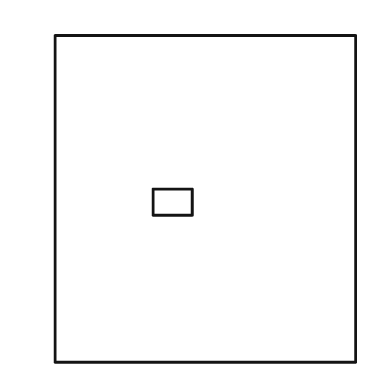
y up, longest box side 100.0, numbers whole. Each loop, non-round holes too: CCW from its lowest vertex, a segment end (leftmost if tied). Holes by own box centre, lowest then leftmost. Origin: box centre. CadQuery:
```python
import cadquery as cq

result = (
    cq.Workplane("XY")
    .moveTo(-46.0, -50.0)
    .lineTo(46.0, -50.0)
    .lineTo(46.0, 50.0)
    .lineTo(-46.0, 50.0)
    .close()
    .moveTo(-16.0, -5.0)
    .lineTo(-4.0, -5.0)
    .lineTo(-4.0, 3.0)
    .lineTo(-16.0, 3.0)
    .close()
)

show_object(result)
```